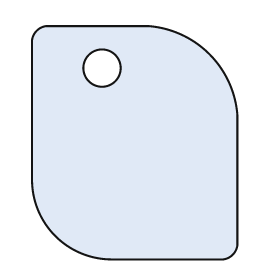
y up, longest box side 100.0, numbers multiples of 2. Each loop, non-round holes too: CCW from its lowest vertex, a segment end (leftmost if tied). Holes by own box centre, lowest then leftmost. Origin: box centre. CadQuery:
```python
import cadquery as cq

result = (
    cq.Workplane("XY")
    .moveTo(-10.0, -50.0)
    .lineTo(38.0, -50.0)
    .threePointArc((42.0, -48.0), (44.0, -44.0))
    .lineTo(44.0, 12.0)
    .threePointArc((32.0, 38.0), (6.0, 50.0))
    .lineTo(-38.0, 50.0)
    .threePointArc((-42.0, 48.0), (-44.0, 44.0))
    .lineTo(-44.0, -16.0)
    .threePointArc((-34.0, -40.0), (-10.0, -50.0))
    .close()
    .moveTo(-14.0, 32.0)
    .circle(8.0)
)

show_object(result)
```